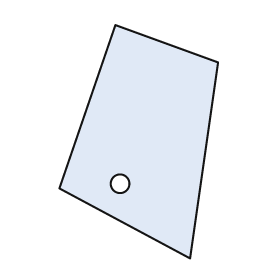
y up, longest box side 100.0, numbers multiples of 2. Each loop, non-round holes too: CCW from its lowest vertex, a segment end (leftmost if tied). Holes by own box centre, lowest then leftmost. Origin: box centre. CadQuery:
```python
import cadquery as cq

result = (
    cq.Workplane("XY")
    .moveTo(22.0, -50.0)
    .lineTo(34.0, 34.0)
    .lineTo(-10.0, 50.0)
    .lineTo(-34.0, -20.0)
    .close()
    .moveTo(-8.0, -18.0)
    .circle(4.0)
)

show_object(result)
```